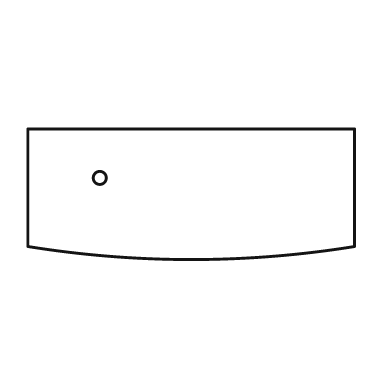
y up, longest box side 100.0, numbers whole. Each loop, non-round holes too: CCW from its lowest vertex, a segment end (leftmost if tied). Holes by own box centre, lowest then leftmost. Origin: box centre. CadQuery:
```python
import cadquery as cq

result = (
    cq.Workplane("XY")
    .moveTo(-50.0, -16.0)
    .threePointArc((0.0, -20.0), (50.0, -16.0))
    .lineTo(50.0, 20.0)
    .lineTo(-50.0, 20.0)
    .close()
    .moveTo(-28.0, 5.0)
    .circle(2.0)
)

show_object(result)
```